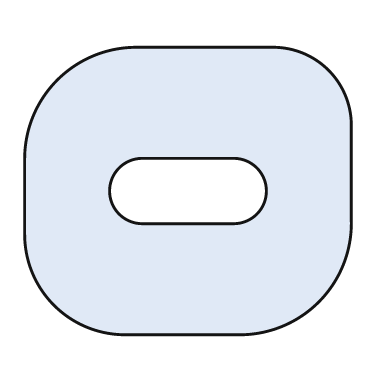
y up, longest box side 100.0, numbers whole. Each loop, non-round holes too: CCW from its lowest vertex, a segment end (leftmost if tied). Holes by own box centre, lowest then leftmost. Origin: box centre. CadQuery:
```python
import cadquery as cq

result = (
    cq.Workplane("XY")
    .moveTo(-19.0, -44.0)
    .lineTo(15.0, -44.0)
    .threePointArc((40.0, -34.0), (50.0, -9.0))
    .lineTo(50.0, 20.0)
    .threePointArc((43.0, 37.0), (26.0, 44.0))
    .lineTo(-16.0, 44.0)
    .threePointArc((-40.0, 34.0), (-50.0, 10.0))
    .lineTo(-50.0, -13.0)
    .threePointArc((-41.0, -35.0), (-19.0, -44.0))
    .close()
    .moveTo(-14.0, -10.0)
    .lineTo(14.0, -10.0)
    .threePointArc((24.0, 0.0), (14.0, 10.0))
    .lineTo(-14.0, 10.0)
    .threePointArc((-24.0, 0.0), (-14.0, -10.0))
    .close()
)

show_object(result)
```